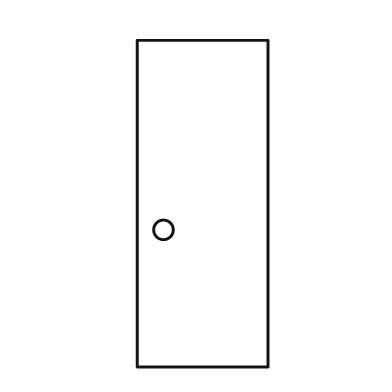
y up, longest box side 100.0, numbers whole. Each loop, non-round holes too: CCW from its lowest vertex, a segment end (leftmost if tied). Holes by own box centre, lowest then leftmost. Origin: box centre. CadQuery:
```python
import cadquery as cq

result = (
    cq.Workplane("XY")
    .moveTo(-20.0, -50.0)
    .lineTo(20.0, -50.0)
    .lineTo(20.0, 50.0)
    .lineTo(-20.0, 50.0)
    .close()
    .moveTo(-12.0, -8.0)
    .circle(3.0)
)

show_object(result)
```